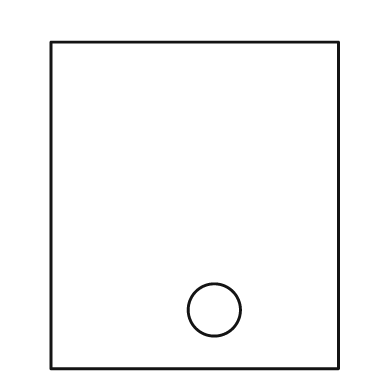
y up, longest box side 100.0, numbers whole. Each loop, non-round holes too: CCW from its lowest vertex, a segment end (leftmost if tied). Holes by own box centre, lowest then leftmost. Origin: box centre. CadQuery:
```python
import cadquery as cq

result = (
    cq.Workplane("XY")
    .moveTo(-44.0, -50.0)
    .lineTo(44.0, -50.0)
    .lineTo(44.0, 50.0)
    .lineTo(-44.0, 50.0)
    .close()
    .moveTo(6.0, -32.0)
    .circle(8.0)
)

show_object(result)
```